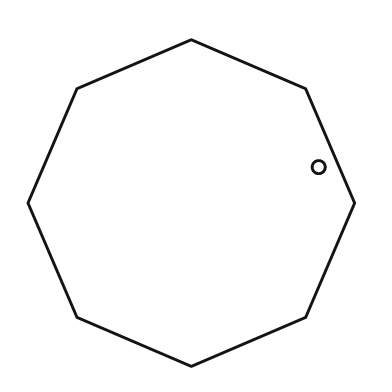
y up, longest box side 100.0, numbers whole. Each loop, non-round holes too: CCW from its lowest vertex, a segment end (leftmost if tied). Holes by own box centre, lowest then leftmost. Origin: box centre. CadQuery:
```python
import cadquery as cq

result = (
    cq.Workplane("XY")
    .moveTo(0.0, -50.0)
    .lineTo(35.0, -35.0)
    .lineTo(50.0, 0.0)
    .lineTo(35.0, 35.0)
    .lineTo(0.0, 50.0)
    .lineTo(-35.0, 35.0)
    .lineTo(-50.0, 0.0)
    .lineTo(-35.0, -35.0)
    .close()
    .moveTo(39.0, 11.0)
    .circle(2.0)
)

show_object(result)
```